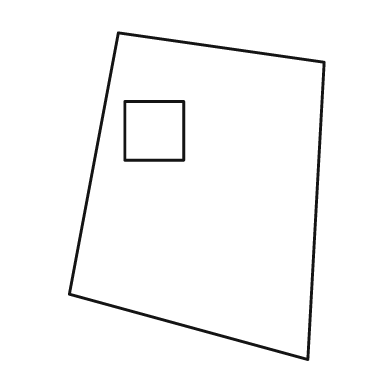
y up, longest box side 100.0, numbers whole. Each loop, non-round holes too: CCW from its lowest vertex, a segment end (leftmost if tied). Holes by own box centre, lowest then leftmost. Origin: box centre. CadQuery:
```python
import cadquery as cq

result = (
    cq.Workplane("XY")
    .moveTo(34.0, -50.0)
    .lineTo(39.0, 41.0)
    .lineTo(-24.0, 50.0)
    .lineTo(-39.0, -30.0)
    .close()
    .moveTo(-22.0, 11.0)
    .lineTo(-4.0, 11.0)
    .lineTo(-4.0, 29.0)
    .lineTo(-22.0, 29.0)
    .close()
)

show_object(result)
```